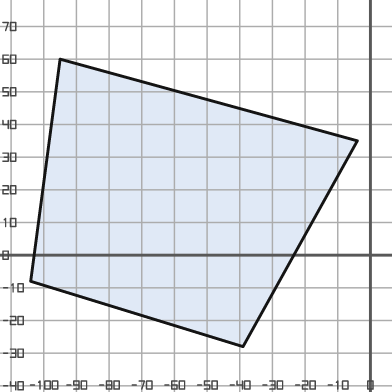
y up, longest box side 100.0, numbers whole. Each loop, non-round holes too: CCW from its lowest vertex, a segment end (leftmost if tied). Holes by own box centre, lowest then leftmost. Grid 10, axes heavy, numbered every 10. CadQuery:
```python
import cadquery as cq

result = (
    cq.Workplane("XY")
    .moveTo(-39.0, -28.0)
    .lineTo(-4.0, 35.0)
    .lineTo(-95.0, 60.0)
    .lineTo(-104.0, -8.0)
    .close()
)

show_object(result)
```